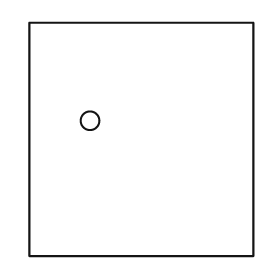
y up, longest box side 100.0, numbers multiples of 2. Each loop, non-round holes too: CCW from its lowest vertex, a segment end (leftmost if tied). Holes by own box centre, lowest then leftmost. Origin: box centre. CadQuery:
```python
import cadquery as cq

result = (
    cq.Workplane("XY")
    .moveTo(-48.0, -50.0)
    .lineTo(48.0, -50.0)
    .lineTo(48.0, 50.0)
    .lineTo(-48.0, 50.0)
    .close()
    .moveTo(-22.0, 8.0)
    .circle(4.0)
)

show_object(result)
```